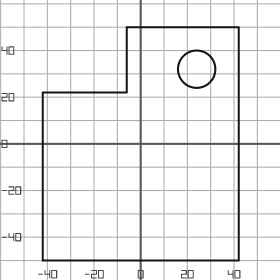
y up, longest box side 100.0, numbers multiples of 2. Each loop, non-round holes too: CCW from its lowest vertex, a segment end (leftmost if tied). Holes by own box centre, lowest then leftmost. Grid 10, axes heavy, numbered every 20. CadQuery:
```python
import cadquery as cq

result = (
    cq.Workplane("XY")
    .moveTo(-42.0, -50.0)
    .lineTo(42.0, -50.0)
    .lineTo(42.0, 50.0)
    .lineTo(-6.0, 50.0)
    .lineTo(-6.0, 22.0)
    .lineTo(-42.0, 22.0)
    .close()
    .moveTo(24.0, 32.0)
    .circle(8.0)
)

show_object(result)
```